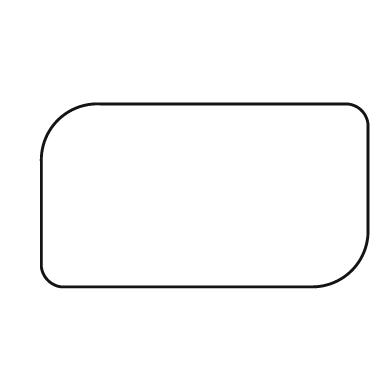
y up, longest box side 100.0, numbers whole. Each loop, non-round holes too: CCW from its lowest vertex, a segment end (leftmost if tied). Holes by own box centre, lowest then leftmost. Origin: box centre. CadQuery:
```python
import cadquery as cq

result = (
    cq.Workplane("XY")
    .moveTo(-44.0, -28.0)
    .lineTo(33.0, -28.0)
    .threePointArc((45.0, -23.0), (50.0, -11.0))
    .lineTo(50.0, 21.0)
    .threePointArc((48.0, 26.0), (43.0, 28.0))
    .lineTo(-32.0, 28.0)
    .threePointArc((-45.0, 23.0), (-50.0, 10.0))
    .lineTo(-50.0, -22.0)
    .threePointArc((-48.0, -26.0), (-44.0, -28.0))
    .close()
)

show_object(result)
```